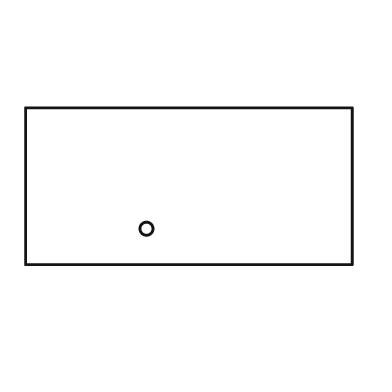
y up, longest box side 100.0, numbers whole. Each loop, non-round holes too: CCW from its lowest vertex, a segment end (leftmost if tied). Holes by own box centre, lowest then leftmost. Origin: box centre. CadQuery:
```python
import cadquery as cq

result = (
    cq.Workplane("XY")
    .moveTo(-50.0, -24.0)
    .lineTo(50.0, -24.0)
    .lineTo(50.0, 24.0)
    .lineTo(-50.0, 24.0)
    .close()
    .moveTo(-13.0, -13.0)
    .circle(2.0)
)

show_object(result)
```